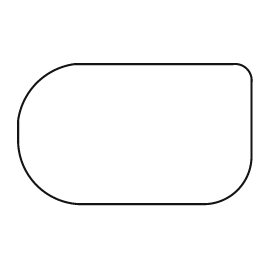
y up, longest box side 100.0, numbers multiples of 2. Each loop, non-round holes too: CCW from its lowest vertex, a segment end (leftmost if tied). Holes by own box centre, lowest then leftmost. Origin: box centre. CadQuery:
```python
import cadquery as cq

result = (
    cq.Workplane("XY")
    .moveTo(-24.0, -30.0)
    .lineTo(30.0, -30.0)
    .threePointArc((44.0, -24.0), (50.0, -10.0))
    .lineTo(50.0, 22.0)
    .threePointArc((48.0, 28.0), (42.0, 30.0))
    .lineTo(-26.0, 30.0)
    .threePointArc((-42.0, 22.0), (-50.0, 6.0))
    .lineTo(-50.0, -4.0)
    .threePointArc((-42.0, -22.0), (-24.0, -30.0))
    .close()
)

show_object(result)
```